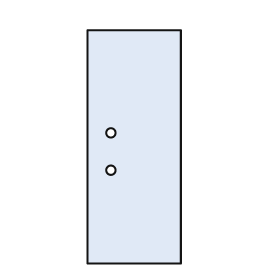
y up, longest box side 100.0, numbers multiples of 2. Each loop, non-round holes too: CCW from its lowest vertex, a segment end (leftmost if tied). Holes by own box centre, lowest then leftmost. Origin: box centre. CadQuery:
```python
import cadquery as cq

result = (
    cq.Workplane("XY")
    .moveTo(-20.0, -50.0)
    .lineTo(20.0, -50.0)
    .lineTo(20.0, 50.0)
    .lineTo(-20.0, 50.0)
    .close()
    .moveTo(-10.0, -10.0)
    .circle(2.0)
    .moveTo(-10.0, 6.0)
    .circle(2.0)
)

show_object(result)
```